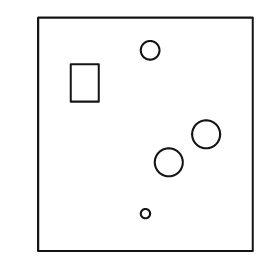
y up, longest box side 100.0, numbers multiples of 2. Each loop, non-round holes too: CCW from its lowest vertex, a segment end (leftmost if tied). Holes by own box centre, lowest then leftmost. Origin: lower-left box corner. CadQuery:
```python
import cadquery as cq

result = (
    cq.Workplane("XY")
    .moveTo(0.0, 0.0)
    .lineTo(92.0, 0.0)
    .lineTo(92.0, 100.0)
    .lineTo(0.0, 100.0)
    .close()
    .moveTo(46.0, 16.0)
    .circle(2.0)
    .moveTo(56.0, 38.0)
    .circle(6.0)
    .moveTo(72.0, 50.0)
    .circle(6.0)
    .moveTo(14.0, 64.0)
    .lineTo(26.0, 64.0)
    .lineTo(26.0, 80.0)
    .lineTo(14.0, 80.0)
    .close()
    .moveTo(48.0, 86.0)
    .circle(4.0)
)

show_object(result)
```